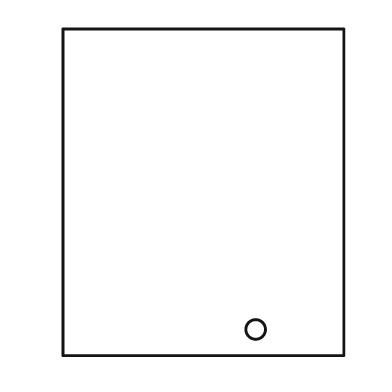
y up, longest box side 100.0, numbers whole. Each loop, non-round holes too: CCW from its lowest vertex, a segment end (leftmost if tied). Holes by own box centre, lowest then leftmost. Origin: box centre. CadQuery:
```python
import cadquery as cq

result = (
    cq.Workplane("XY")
    .moveTo(-43.0, -50.0)
    .lineTo(43.0, -50.0)
    .lineTo(43.0, 50.0)
    .lineTo(-43.0, 50.0)
    .close()
    .moveTo(16.0, -42.0)
    .circle(3.0)
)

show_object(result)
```